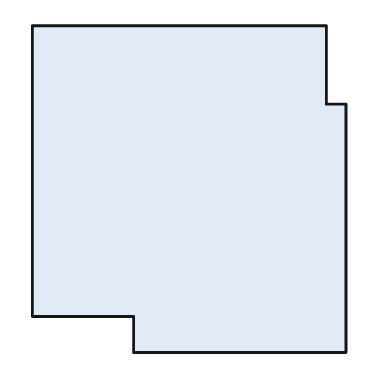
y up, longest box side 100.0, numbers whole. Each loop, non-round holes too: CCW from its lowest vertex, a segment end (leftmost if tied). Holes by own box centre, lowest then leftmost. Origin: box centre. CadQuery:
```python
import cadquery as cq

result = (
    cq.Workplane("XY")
    .moveTo(-17.0, -50.0)
    .lineTo(48.0, -50.0)
    .lineTo(48.0, 26.0)
    .lineTo(42.0, 26.0)
    .lineTo(42.0, 50.0)
    .lineTo(-48.0, 50.0)
    .lineTo(-48.0, -39.0)
    .lineTo(-17.0, -39.0)
    .close()
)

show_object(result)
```